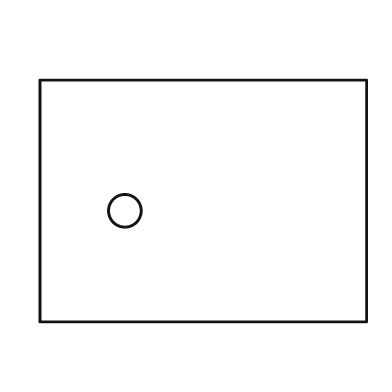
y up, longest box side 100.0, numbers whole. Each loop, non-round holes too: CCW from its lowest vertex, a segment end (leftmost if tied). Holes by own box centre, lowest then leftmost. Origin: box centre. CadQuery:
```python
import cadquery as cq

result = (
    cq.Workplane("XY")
    .moveTo(-50.0, -37.0)
    .lineTo(50.0, -37.0)
    .lineTo(50.0, 37.0)
    .lineTo(-50.0, 37.0)
    .close()
    .moveTo(-24.0, -3.0)
    .circle(5.0)
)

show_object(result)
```